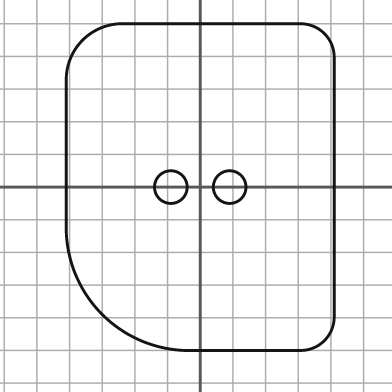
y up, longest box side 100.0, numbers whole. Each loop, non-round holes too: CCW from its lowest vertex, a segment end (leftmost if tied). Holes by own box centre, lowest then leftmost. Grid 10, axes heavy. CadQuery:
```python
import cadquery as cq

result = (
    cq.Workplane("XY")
    .moveTo(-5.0, -50.0)
    .lineTo(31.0, -50.0)
    .threePointArc((38.0, -47.0), (41.0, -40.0))
    .lineTo(41.0, 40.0)
    .threePointArc((38.0, 47.0), (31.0, 50.0))
    .lineTo(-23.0, 50.0)
    .threePointArc((-36.0, 45.0), (-41.0, 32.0))
    .lineTo(-41.0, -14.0)
    .threePointArc((-30.0, -39.0), (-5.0, -50.0))
    .close()
    .moveTo(-9.0, 0.0)
    .circle(5.0)
    .moveTo(9.0, 0.0)
    .circle(5.0)
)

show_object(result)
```